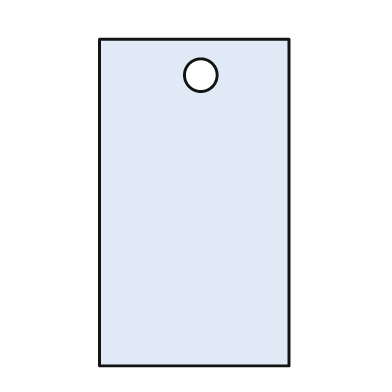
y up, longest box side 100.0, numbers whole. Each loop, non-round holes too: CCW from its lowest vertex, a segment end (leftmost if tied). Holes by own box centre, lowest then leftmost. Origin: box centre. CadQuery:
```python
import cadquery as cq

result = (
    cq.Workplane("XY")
    .moveTo(-29.0, -50.0)
    .lineTo(29.0, -50.0)
    .lineTo(29.0, 50.0)
    .lineTo(-29.0, 50.0)
    .close()
    .moveTo(2.0, 39.0)
    .circle(5.0)
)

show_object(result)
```